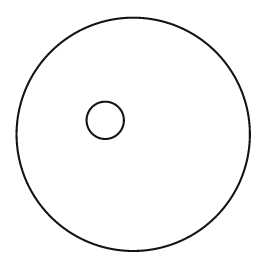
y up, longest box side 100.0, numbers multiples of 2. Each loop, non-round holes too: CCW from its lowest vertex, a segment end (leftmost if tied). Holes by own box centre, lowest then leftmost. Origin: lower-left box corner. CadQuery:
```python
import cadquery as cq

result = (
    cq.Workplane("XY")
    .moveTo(50.0, 50.0)
    .circle(50.0)
    .moveTo(38.0, 56.0)
    .circle(8.0)
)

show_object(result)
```